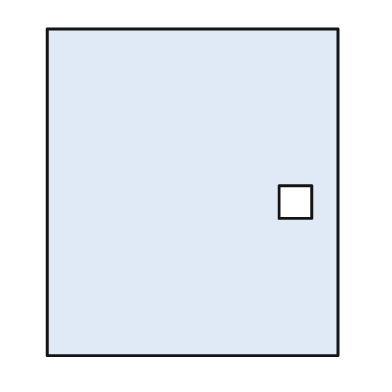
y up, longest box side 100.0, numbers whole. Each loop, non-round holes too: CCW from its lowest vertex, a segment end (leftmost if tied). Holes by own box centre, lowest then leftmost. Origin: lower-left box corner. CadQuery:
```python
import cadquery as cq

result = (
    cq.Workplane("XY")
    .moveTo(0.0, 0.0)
    .lineTo(89.0, 0.0)
    .lineTo(89.0, 100.0)
    .lineTo(0.0, 100.0)
    .close()
    .moveTo(71.0, 42.0)
    .lineTo(81.0, 42.0)
    .lineTo(81.0, 52.0)
    .lineTo(71.0, 52.0)
    .close()
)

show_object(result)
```